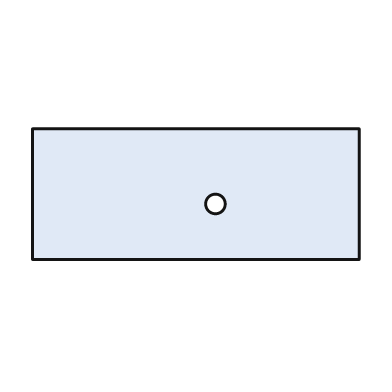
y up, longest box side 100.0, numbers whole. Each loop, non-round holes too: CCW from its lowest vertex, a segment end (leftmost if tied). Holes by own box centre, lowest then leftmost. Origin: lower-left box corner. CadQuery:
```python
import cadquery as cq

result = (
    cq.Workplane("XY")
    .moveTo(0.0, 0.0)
    .lineTo(100.0, 0.0)
    .lineTo(100.0, 40.0)
    .lineTo(0.0, 40.0)
    .close()
    .moveTo(56.0, 17.0)
    .circle(3.0)
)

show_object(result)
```